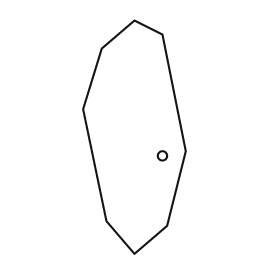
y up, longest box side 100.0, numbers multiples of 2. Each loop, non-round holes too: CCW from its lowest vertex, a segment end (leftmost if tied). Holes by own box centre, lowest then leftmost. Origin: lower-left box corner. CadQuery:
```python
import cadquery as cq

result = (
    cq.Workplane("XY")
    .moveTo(22.0, 0.0)
    .lineTo(36.0, 12.0)
    .lineTo(44.0, 44.0)
    .lineTo(34.0, 94.0)
    .lineTo(22.0, 100.0)
    .lineTo(8.0, 88.0)
    .lineTo(0.0, 62.0)
    .lineTo(10.0, 14.0)
    .close()
    .moveTo(34.0, 42.0)
    .circle(2.0)
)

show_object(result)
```